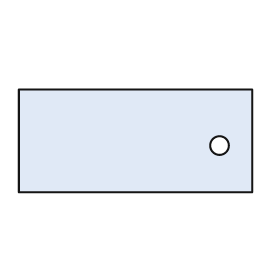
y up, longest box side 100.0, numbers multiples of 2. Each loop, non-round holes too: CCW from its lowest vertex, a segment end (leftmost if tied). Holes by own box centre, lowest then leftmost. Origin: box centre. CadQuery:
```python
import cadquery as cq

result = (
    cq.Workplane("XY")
    .moveTo(-50.0, -22.0)
    .lineTo(50.0, -22.0)
    .lineTo(50.0, 22.0)
    .lineTo(-50.0, 22.0)
    .close()
    .moveTo(36.0, -2.0)
    .circle(4.0)
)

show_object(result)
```